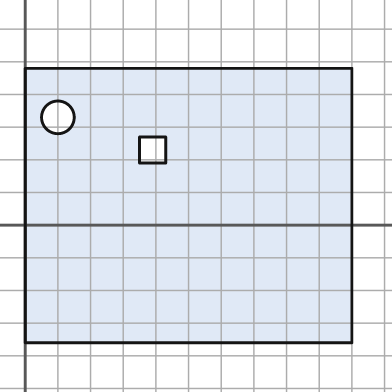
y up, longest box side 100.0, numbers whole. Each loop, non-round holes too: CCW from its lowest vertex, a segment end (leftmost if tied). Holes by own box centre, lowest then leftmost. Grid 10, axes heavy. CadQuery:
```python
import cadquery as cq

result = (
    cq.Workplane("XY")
    .moveTo(0.0, -36.0)
    .lineTo(100.0, -36.0)
    .lineTo(100.0, 48.0)
    .lineTo(0.0, 48.0)
    .close()
    .moveTo(35.0, 19.0)
    .lineTo(43.0, 19.0)
    .lineTo(43.0, 27.0)
    .lineTo(35.0, 27.0)
    .close()
    .moveTo(10.0, 33.0)
    .circle(5.0)
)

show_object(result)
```